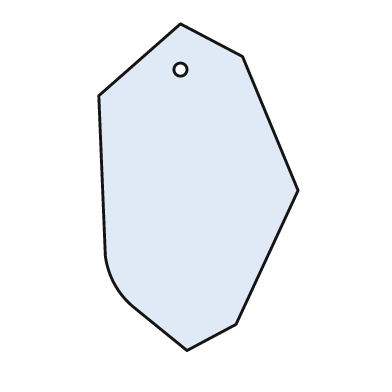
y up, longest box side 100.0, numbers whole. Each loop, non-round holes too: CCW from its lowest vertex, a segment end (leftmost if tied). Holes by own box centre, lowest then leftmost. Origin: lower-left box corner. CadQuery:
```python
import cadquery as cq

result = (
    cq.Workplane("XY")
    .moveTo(27.0, 0.0)
    .lineTo(42.0, 8.0)
    .lineTo(61.0, 49.0)
    .lineTo(44.0, 90.0)
    .lineTo(25.0, 100.0)
    .lineTo(0.0, 78.0)
    .lineTo(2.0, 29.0)
    .threePointArc((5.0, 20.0), (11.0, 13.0))
    .close()
    .moveTo(25.0, 86.0)
    .circle(2.0)
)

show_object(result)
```